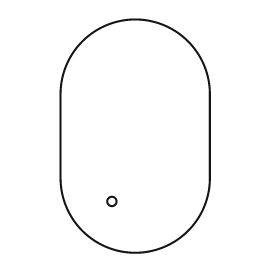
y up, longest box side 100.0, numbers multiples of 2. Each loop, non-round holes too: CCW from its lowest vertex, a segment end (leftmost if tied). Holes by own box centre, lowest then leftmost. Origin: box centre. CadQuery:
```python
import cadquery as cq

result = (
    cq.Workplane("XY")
    .moveTo(-32.0, -18.0)
    .threePointArc((0.0, -50.0), (32.0, -18.0))
    .lineTo(32.0, 18.0)
    .threePointArc((0.0, 50.0), (-32.0, 18.0))
    .close()
    .moveTo(-10.0, -28.0)
    .circle(2.0)
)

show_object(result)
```